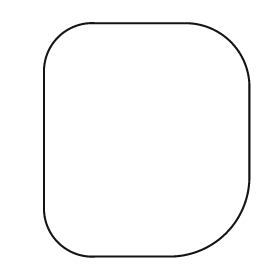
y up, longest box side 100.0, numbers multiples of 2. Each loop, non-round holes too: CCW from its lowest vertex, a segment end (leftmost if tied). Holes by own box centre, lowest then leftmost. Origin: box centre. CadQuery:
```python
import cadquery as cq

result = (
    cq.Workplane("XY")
    .moveTo(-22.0, -50.0)
    .lineTo(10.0, -50.0)
    .threePointArc((34.0, -40.0), (44.0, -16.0))
    .lineTo(44.0, 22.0)
    .threePointArc((36.0, 42.0), (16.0, 50.0))
    .lineTo(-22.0, 50.0)
    .threePointArc((-38.0, 44.0), (-44.0, 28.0))
    .lineTo(-44.0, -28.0)
    .threePointArc((-38.0, -44.0), (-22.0, -50.0))
    .close()
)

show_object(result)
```